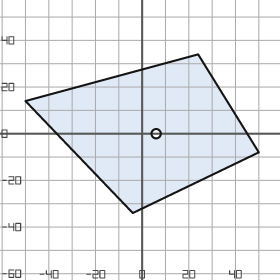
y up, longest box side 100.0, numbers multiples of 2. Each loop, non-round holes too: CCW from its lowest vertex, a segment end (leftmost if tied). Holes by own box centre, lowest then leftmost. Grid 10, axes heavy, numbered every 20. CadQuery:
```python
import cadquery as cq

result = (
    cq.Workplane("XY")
    .moveTo(-4.0, -34.0)
    .lineTo(50.0, -8.0)
    .lineTo(24.0, 34.0)
    .lineTo(-50.0, 14.0)
    .close()
    .moveTo(6.0, 0.0)
    .circle(2.0)
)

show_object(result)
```